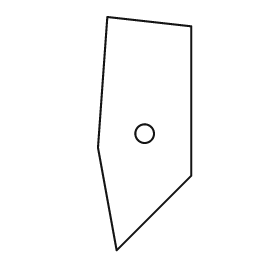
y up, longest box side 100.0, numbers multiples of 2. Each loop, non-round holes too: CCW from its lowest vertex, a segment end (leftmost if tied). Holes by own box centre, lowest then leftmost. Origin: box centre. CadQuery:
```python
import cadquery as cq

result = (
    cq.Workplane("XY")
    .moveTo(-12.0, -50.0)
    .lineTo(20.0, -18.0)
    .lineTo(20.0, 46.0)
    .lineTo(-16.0, 50.0)
    .lineTo(-20.0, -6.0)
    .close()
    .moveTo(0.0, 0.0)
    .circle(4.0)
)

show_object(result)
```